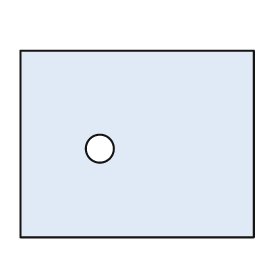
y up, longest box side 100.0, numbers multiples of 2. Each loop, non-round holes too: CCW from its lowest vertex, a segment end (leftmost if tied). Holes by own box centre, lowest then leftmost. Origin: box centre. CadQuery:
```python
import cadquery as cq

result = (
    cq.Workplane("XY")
    .moveTo(-50.0, -40.0)
    .lineTo(50.0, -40.0)
    .lineTo(50.0, 40.0)
    .lineTo(-50.0, 40.0)
    .close()
    .moveTo(-16.0, -2.0)
    .circle(6.0)
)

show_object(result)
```